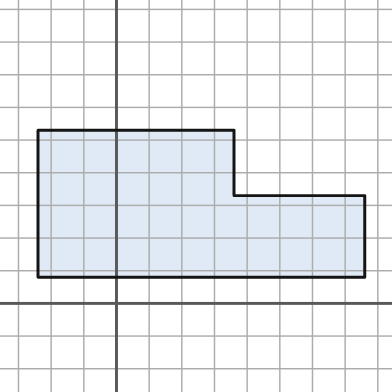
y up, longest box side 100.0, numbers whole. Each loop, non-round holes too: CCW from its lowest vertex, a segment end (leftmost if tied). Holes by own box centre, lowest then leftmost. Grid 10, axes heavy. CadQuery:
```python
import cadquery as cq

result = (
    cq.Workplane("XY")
    .moveTo(-24.0, 8.0)
    .lineTo(76.0, 8.0)
    .lineTo(76.0, 33.0)
    .lineTo(36.0, 33.0)
    .lineTo(36.0, 53.0)
    .lineTo(-24.0, 53.0)
    .close()
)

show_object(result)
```